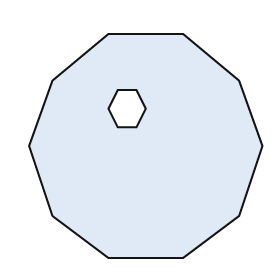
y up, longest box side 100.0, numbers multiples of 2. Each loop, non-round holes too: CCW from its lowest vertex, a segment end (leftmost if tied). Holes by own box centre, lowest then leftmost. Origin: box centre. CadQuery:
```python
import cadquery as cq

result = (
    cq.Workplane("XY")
    .moveTo(-16.0, -48.0)
    .lineTo(16.0, -48.0)
    .lineTo(40.0, -30.0)
    .lineTo(50.0, 0.0)
    .lineTo(40.0, 28.0)
    .lineTo(16.0, 48.0)
    .lineTo(-16.0, 48.0)
    .lineTo(-40.0, 28.0)
    .lineTo(-50.0, 0.0)
    .lineTo(-40.0, -30.0)
    .close()
    .moveTo(-12.0, 8.0)
    .lineTo(-4.0, 8.0)
    .lineTo(0.0, 16.0)
    .lineTo(-4.0, 24.0)
    .lineTo(-12.0, 24.0)
    .lineTo(-16.0, 16.0)
    .close()
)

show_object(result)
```